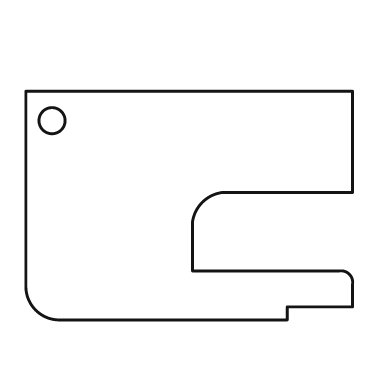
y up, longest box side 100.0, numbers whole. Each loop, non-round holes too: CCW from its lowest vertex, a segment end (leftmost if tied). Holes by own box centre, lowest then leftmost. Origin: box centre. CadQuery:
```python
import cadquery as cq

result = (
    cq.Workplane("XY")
    .moveTo(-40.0, -35.0)
    .lineTo(30.0, -35.0)
    .lineTo(30.0, -31.0)
    .lineTo(50.0, -31.0)
    .lineTo(50.0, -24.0)
    .threePointArc((49.0, -21.0), (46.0, -20.0))
    .lineTo(1.0, -20.0)
    .lineTo(1.0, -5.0)
    .threePointArc((4.0, 1.0), (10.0, 4.0))
    .lineTo(50.0, 4.0)
    .lineTo(50.0, 35.0)
    .lineTo(-50.0, 35.0)
    .lineTo(-50.0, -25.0)
    .threePointArc((-47.0, -32.0), (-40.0, -35.0))
    .close()
    .moveTo(-42.0, 26.0)
    .circle(4.0)
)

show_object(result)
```